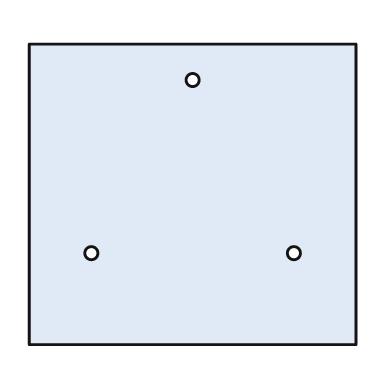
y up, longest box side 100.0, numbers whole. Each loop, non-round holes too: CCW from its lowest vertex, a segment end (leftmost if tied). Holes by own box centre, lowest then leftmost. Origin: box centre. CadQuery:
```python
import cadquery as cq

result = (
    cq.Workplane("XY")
    .moveTo(-50.0, -46.0)
    .lineTo(50.0, -46.0)
    .lineTo(50.0, 46.0)
    .lineTo(-50.0, 46.0)
    .close()
    .moveTo(-31.0, -18.0)
    .circle(2.0)
    .moveTo(31.0, -18.0)
    .circle(2.0)
    .moveTo(0.0, 35.0)
    .circle(2.0)
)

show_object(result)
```